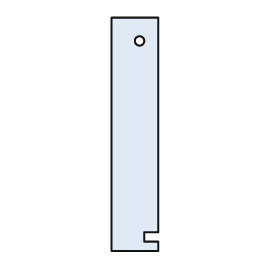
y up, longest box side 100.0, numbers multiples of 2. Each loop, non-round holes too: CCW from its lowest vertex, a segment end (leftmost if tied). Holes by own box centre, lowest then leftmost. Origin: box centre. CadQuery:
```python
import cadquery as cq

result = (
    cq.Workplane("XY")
    .moveTo(-10.0, -50.0)
    .lineTo(10.0, -50.0)
    .lineTo(10.0, -46.0)
    .lineTo(4.0, -46.0)
    .lineTo(4.0, -42.0)
    .lineTo(10.0, -42.0)
    .lineTo(10.0, 50.0)
    .lineTo(-10.0, 50.0)
    .close()
    .moveTo(2.0, 40.0)
    .circle(2.0)
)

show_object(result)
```